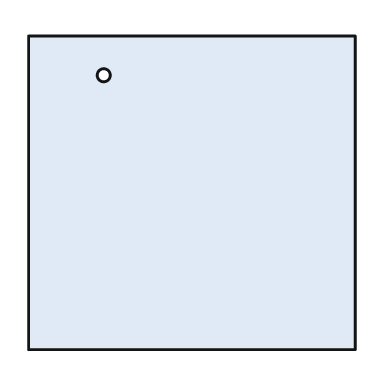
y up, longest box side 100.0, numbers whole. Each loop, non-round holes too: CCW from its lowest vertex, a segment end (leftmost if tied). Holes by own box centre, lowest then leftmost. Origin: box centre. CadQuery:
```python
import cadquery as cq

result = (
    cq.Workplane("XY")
    .moveTo(-50.0, -48.0)
    .lineTo(50.0, -48.0)
    .lineTo(50.0, 48.0)
    .lineTo(-50.0, 48.0)
    .close()
    .moveTo(-27.0, 36.0)
    .circle(2.0)
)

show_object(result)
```